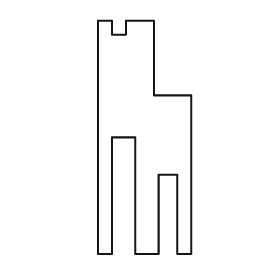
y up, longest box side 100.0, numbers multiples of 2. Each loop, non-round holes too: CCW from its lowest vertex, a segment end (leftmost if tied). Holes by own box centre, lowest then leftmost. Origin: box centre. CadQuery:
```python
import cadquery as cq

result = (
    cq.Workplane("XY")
    .moveTo(-20.0, -50.0)
    .lineTo(-14.0, -50.0)
    .lineTo(-14.0, 0.0)
    .lineTo(-4.0, 0.0)
    .lineTo(-4.0, -50.0)
    .lineTo(6.0, -50.0)
    .lineTo(6.0, -16.0)
    .lineTo(14.0, -16.0)
    .lineTo(14.0, -50.0)
    .lineTo(20.0, -50.0)
    .lineTo(20.0, 18.0)
    .lineTo(4.0, 18.0)
    .lineTo(4.0, 50.0)
    .lineTo(-8.0, 50.0)
    .lineTo(-8.0, 44.0)
    .lineTo(-14.0, 44.0)
    .lineTo(-14.0, 50.0)
    .lineTo(-20.0, 50.0)
    .close()
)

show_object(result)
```